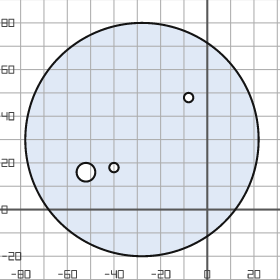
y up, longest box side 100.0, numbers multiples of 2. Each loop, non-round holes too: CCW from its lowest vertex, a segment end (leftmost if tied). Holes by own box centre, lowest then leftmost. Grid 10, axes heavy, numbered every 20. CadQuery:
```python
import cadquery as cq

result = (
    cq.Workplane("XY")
    .moveTo(-28.0, 30.0)
    .circle(50.0)
    .moveTo(-52.0, 16.0)
    .circle(4.0)
    .moveTo(-40.0, 18.0)
    .circle(2.0)
    .moveTo(-8.0, 48.0)
    .circle(2.0)
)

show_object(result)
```